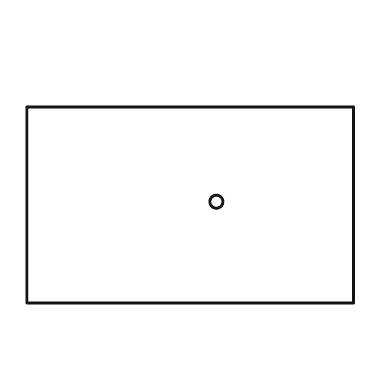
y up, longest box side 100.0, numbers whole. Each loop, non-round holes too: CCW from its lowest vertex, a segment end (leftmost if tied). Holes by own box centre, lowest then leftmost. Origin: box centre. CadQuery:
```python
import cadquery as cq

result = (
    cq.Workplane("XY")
    .moveTo(-50.0, -30.0)
    .lineTo(50.0, -30.0)
    .lineTo(50.0, 30.0)
    .lineTo(-50.0, 30.0)
    .close()
    .moveTo(8.0, 1.0)
    .circle(2.0)
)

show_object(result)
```